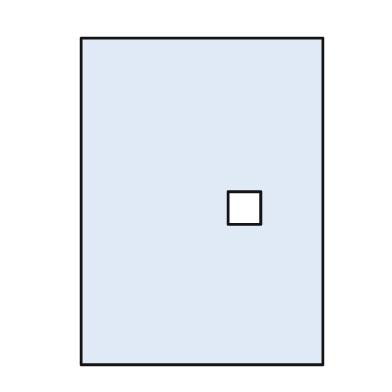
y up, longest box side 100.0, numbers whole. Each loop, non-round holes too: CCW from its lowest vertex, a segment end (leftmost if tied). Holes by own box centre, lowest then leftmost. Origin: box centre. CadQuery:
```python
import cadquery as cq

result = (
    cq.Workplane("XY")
    .moveTo(-37.0, -50.0)
    .lineTo(37.0, -50.0)
    .lineTo(37.0, 50.0)
    .lineTo(-37.0, 50.0)
    .close()
    .moveTo(8.0, -7.0)
    .lineTo(18.0, -7.0)
    .lineTo(18.0, 3.0)
    .lineTo(8.0, 3.0)
    .close()
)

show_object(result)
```